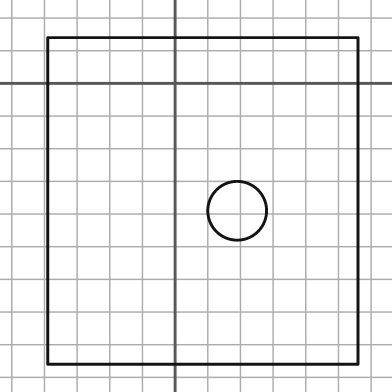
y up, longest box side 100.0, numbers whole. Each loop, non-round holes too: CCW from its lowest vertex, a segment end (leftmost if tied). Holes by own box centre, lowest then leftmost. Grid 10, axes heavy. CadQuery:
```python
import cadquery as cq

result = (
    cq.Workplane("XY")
    .moveTo(-39.0, -86.0)
    .lineTo(56.0, -86.0)
    .lineTo(56.0, 14.0)
    .lineTo(-39.0, 14.0)
    .close()
    .moveTo(19.0, -39.0)
    .circle(9.0)
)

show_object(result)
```